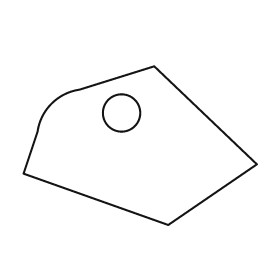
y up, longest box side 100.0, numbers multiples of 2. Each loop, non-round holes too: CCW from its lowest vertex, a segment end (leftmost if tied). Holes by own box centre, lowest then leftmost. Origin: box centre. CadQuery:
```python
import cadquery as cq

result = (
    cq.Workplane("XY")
    .moveTo(12.0, -34.0)
    .lineTo(50.0, -8.0)
    .lineTo(6.0, 34.0)
    .lineTo(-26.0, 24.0)
    .threePointArc((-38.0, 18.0), (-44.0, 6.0))
    .lineTo(-50.0, -12.0)
    .close()
    .moveTo(-8.0, 14.0)
    .circle(8.0)
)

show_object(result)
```